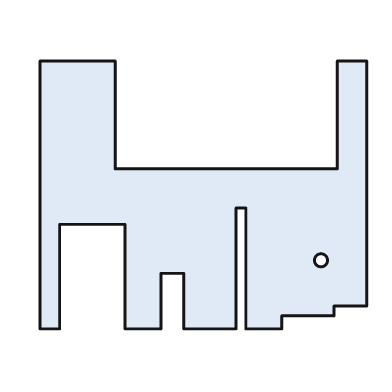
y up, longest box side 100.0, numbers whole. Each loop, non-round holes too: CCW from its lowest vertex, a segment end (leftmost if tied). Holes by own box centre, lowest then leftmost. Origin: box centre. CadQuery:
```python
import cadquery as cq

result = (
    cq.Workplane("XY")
    .moveTo(-50.0, -41.0)
    .lineTo(-44.0, -41.0)
    .lineTo(-44.0, -9.0)
    .lineTo(-24.0, -9.0)
    .lineTo(-24.0, -41.0)
    .lineTo(-13.0, -41.0)
    .lineTo(-13.0, -24.0)
    .lineTo(-6.0, -24.0)
    .lineTo(-6.0, -41.0)
    .lineTo(10.0, -41.0)
    .lineTo(10.0, -4.0)
    .lineTo(13.0, -4.0)
    .lineTo(13.0, -41.0)
    .lineTo(24.0, -41.0)
    .lineTo(24.0, -37.0)
    .lineTo(40.0, -37.0)
    .lineTo(40.0, -34.0)
    .lineTo(50.0, -34.0)
    .lineTo(50.0, 41.0)
    .lineTo(41.0, 41.0)
    .lineTo(41.0, 8.0)
    .lineTo(-27.0, 8.0)
    .lineTo(-27.0, 41.0)
    .lineTo(-50.0, 41.0)
    .close()
    .moveTo(36.0, -20.0)
    .circle(2.0)
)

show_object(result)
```